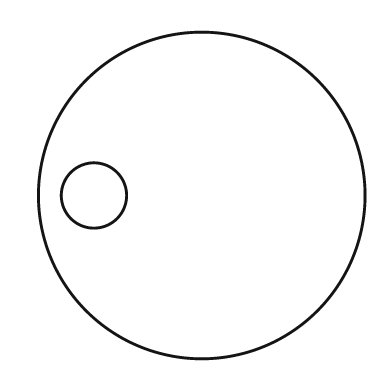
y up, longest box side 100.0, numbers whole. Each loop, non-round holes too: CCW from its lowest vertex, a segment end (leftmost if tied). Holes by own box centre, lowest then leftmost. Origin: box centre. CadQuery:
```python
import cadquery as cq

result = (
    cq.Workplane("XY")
    .moveTo(0.0, 0.0)
    .circle(50.0)
    .moveTo(-33.0, 0.0)
    .circle(10.0)
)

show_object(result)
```